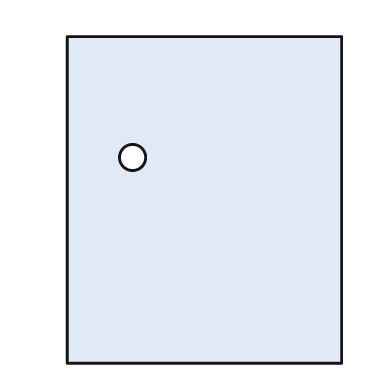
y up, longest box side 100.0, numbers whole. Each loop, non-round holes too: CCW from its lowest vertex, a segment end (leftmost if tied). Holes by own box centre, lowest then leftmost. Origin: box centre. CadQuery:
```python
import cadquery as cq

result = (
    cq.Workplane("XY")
    .moveTo(-42.0, -50.0)
    .lineTo(42.0, -50.0)
    .lineTo(42.0, 50.0)
    .lineTo(-42.0, 50.0)
    .close()
    .moveTo(-22.0, 13.0)
    .circle(4.0)
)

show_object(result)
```